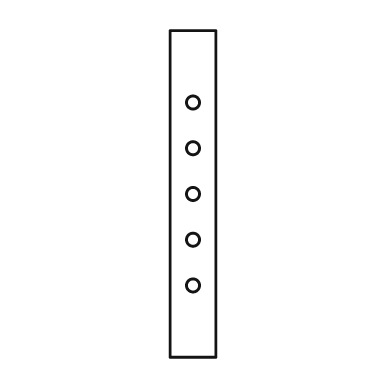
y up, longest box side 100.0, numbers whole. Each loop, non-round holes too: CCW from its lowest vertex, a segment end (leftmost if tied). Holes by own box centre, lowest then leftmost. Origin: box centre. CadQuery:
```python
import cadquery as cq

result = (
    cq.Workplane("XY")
    .moveTo(-7.0, -50.0)
    .lineTo(7.0, -50.0)
    .lineTo(7.0, 50.0)
    .lineTo(-7.0, 50.0)
    .close()
    .moveTo(0.0, -28.0)
    .circle(2.0)
    .moveTo(0.0, -14.0)
    .circle(2.0)
    .moveTo(0.0, 0.0)
    .circle(2.0)
    .moveTo(0.0, 14.0)
    .circle(2.0)
    .moveTo(0.0, 28.0)
    .circle(2.0)
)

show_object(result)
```